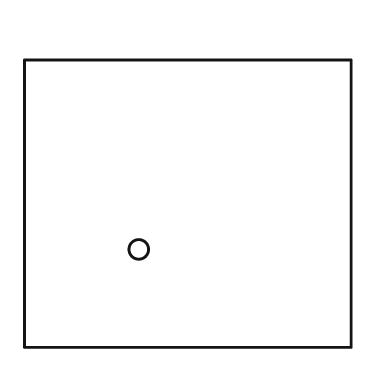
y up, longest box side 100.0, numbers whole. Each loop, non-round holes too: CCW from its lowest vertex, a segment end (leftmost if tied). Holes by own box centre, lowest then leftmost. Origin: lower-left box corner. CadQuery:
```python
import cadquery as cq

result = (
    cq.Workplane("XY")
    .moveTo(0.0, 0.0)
    .lineTo(100.0, 0.0)
    .lineTo(100.0, 88.0)
    .lineTo(0.0, 88.0)
    .close()
    .moveTo(35.0, 30.0)
    .circle(3.0)
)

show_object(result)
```